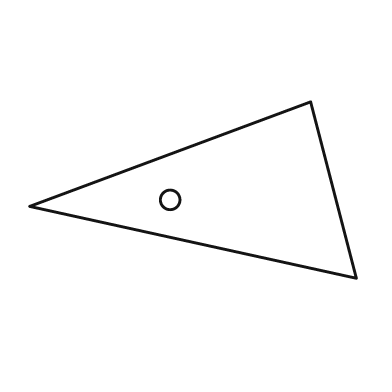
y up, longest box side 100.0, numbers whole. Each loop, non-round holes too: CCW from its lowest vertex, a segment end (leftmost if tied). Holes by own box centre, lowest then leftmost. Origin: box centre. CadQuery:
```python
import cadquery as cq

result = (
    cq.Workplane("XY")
    .moveTo(50.0, -27.0)
    .lineTo(36.0, 27.0)
    .lineTo(-50.0, -5.0)
    .close()
    .moveTo(-7.0, -3.0)
    .circle(3.0)
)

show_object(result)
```